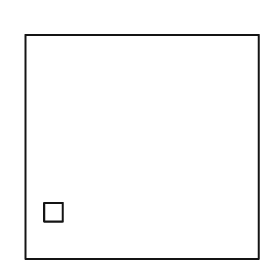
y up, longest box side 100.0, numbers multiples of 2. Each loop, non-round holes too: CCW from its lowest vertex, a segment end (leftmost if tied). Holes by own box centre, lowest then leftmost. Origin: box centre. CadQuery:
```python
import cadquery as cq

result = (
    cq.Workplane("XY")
    .moveTo(-50.0, -48.0)
    .lineTo(50.0, -48.0)
    .lineTo(50.0, 48.0)
    .lineTo(-50.0, 48.0)
    .close()
    .moveTo(-42.0, -32.0)
    .lineTo(-34.0, -32.0)
    .lineTo(-34.0, -24.0)
    .lineTo(-42.0, -24.0)
    .close()
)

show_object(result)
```